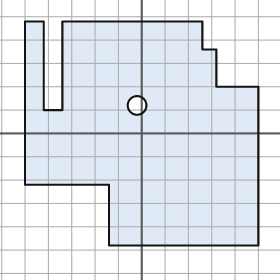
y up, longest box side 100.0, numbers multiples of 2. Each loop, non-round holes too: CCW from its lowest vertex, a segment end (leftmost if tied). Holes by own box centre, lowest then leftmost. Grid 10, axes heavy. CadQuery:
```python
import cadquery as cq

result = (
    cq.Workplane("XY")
    .moveTo(-14.0, -48.0)
    .lineTo(50.0, -48.0)
    .lineTo(50.0, 20.0)
    .lineTo(32.0, 20.0)
    .lineTo(32.0, 36.0)
    .lineTo(26.0, 36.0)
    .lineTo(26.0, 48.0)
    .lineTo(-34.0, 48.0)
    .lineTo(-34.0, 10.0)
    .lineTo(-42.0, 10.0)
    .lineTo(-42.0, 48.0)
    .lineTo(-50.0, 48.0)
    .lineTo(-50.0, -22.0)
    .lineTo(-14.0, -22.0)
    .close()
    .moveTo(-2.0, 12.0)
    .circle(4.0)
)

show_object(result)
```